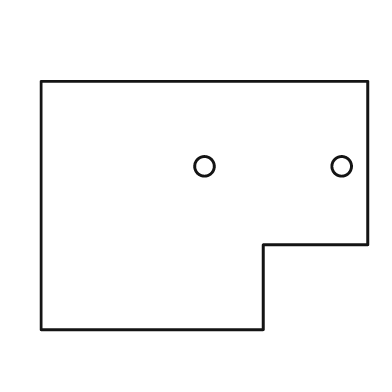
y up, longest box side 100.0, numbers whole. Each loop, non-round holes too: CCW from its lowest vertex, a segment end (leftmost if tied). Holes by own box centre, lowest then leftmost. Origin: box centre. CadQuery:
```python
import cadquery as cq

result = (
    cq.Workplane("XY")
    .moveTo(-50.0, -38.0)
    .lineTo(18.0, -38.0)
    .lineTo(18.0, -12.0)
    .lineTo(50.0, -12.0)
    .lineTo(50.0, 38.0)
    .lineTo(-50.0, 38.0)
    .close()
    .moveTo(0.0, 12.0)
    .circle(3.0)
    .moveTo(42.0, 12.0)
    .circle(3.0)
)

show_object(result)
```